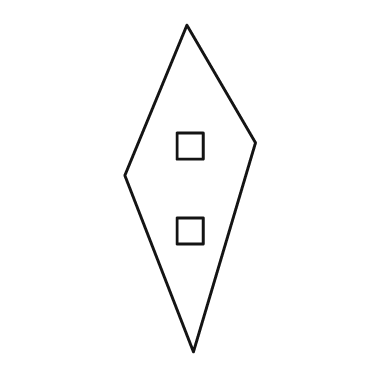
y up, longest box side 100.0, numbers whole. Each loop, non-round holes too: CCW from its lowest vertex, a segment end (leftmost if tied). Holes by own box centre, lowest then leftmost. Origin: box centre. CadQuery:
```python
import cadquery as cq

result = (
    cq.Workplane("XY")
    .moveTo(1.0, -50.0)
    .lineTo(20.0, 14.0)
    .lineTo(-1.0, 50.0)
    .lineTo(-20.0, 4.0)
    .close()
    .moveTo(-4.0, -17.0)
    .lineTo(4.0, -17.0)
    .lineTo(4.0, -9.0)
    .lineTo(-4.0, -9.0)
    .close()
    .moveTo(-4.0, 9.0)
    .lineTo(4.0, 9.0)
    .lineTo(4.0, 17.0)
    .lineTo(-4.0, 17.0)
    .close()
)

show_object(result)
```